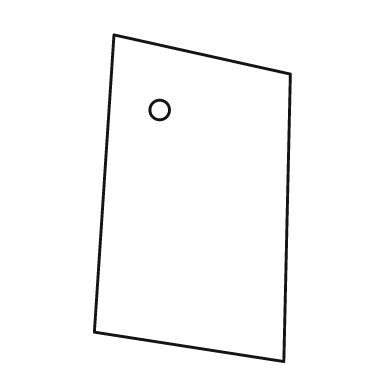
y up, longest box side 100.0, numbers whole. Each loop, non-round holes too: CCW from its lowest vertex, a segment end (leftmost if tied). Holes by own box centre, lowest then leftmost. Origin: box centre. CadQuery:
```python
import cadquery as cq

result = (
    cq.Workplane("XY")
    .moveTo(28.0, -50.0)
    .lineTo(30.0, 38.0)
    .lineTo(-24.0, 50.0)
    .lineTo(-30.0, -41.0)
    .close()
    .moveTo(-10.0, 27.0)
    .circle(3.0)
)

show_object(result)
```